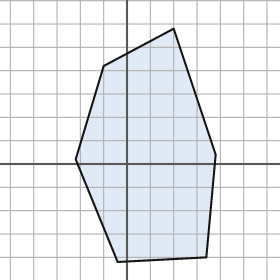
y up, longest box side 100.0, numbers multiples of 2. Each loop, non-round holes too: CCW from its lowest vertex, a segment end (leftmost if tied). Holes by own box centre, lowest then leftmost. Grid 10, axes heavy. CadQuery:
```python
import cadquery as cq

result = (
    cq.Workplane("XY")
    .moveTo(-4.0, -42.0)
    .lineTo(34.0, -40.0)
    .lineTo(38.0, 4.0)
    .lineTo(20.0, 58.0)
    .lineTo(-10.0, 42.0)
    .lineTo(-22.0, 2.0)
    .close()
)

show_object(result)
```